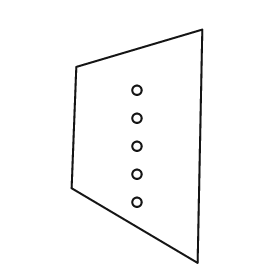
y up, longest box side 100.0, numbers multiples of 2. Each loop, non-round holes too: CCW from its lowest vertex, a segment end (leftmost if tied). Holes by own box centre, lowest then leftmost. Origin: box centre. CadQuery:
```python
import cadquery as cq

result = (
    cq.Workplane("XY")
    .moveTo(26.0, -50.0)
    .lineTo(28.0, 50.0)
    .lineTo(-26.0, 34.0)
    .lineTo(-28.0, -18.0)
    .close()
    .moveTo(0.0, -24.0)
    .circle(2.0)
    .moveTo(0.0, -12.0)
    .circle(2.0)
    .moveTo(0.0, 0.0)
    .circle(2.0)
    .moveTo(0.0, 12.0)
    .circle(2.0)
    .moveTo(0.0, 24.0)
    .circle(2.0)
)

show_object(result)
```